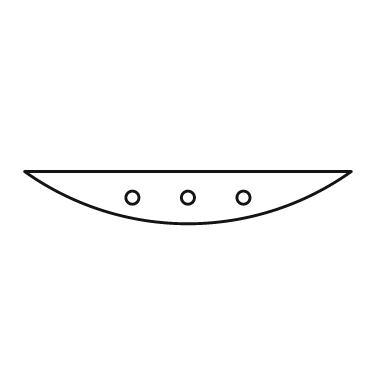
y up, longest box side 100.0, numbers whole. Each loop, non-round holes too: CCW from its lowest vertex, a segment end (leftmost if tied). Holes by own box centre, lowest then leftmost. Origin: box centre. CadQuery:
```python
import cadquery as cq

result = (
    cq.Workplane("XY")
    .moveTo(-50.0, 8.0)
    .threePointArc((0.0, -8.0), (50.0, 8.0))
    .close()
    .moveTo(-17.0, 0.0)
    .circle(2.0)
    .moveTo(0.0, 0.0)
    .circle(2.0)
    .moveTo(17.0, 0.0)
    .circle(2.0)
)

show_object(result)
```